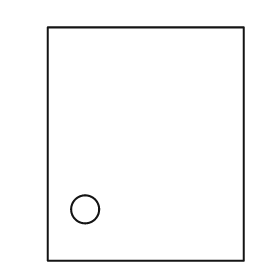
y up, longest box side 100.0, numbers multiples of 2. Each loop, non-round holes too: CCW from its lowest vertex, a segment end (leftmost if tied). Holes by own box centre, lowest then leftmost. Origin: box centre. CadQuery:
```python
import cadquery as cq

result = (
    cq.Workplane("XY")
    .moveTo(-42.0, -50.0)
    .lineTo(42.0, -50.0)
    .lineTo(42.0, 50.0)
    .lineTo(-42.0, 50.0)
    .close()
    .moveTo(-26.0, -28.0)
    .circle(6.0)
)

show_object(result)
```